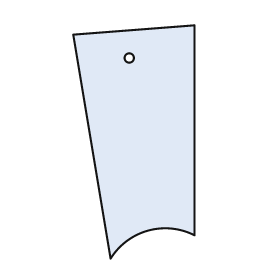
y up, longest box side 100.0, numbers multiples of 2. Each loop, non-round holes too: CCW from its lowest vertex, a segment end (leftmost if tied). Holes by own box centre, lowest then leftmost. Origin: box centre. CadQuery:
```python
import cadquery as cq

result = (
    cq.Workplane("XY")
    .moveTo(-10.0, -50.0)
    .threePointArc((6.0, -38.0), (26.0, -40.0))
    .lineTo(26.0, 50.0)
    .lineTo(-26.0, 46.0)
    .close()
    .moveTo(-2.0, 36.0)
    .circle(2.0)
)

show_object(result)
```